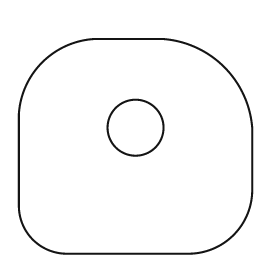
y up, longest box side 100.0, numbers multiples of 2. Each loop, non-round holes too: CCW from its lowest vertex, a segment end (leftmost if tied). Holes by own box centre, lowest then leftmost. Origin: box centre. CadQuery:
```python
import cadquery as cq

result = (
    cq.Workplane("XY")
    .moveTo(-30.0, -46.0)
    .lineTo(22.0, -46.0)
    .threePointArc((42.0, -38.0), (50.0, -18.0))
    .lineTo(50.0, 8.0)
    .threePointArc((38.0, 34.0), (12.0, 46.0))
    .lineTo(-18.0, 46.0)
    .threePointArc((-40.0, 36.0), (-50.0, 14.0))
    .lineTo(-50.0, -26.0)
    .threePointArc((-44.0, -40.0), (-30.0, -46.0))
    .close()
    .moveTo(0.0, 8.0)
    .circle(12.0)
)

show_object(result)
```